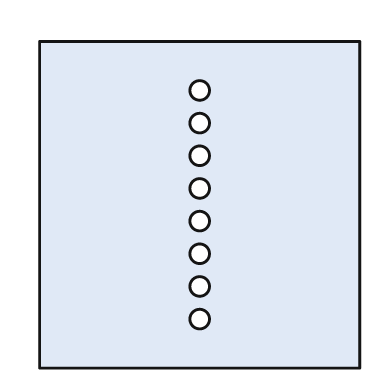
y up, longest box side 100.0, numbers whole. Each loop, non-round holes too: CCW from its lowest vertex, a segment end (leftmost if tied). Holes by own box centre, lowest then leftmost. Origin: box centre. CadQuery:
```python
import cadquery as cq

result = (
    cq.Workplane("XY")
    .moveTo(-49.0, -50.0)
    .lineTo(49.0, -50.0)
    .lineTo(49.0, 50.0)
    .lineTo(-49.0, 50.0)
    .close()
    .moveTo(0.0, -35.0)
    .circle(3.0)
    .moveTo(0.0, -25.0)
    .circle(3.0)
    .moveTo(0.0, -15.0)
    .circle(3.0)
    .moveTo(0.0, -5.0)
    .circle(3.0)
    .moveTo(0.0, 5.0)
    .circle(3.0)
    .moveTo(0.0, 15.0)
    .circle(3.0)
    .moveTo(0.0, 25.0)
    .circle(3.0)
    .moveTo(0.0, 35.0)
    .circle(3.0)
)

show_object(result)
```